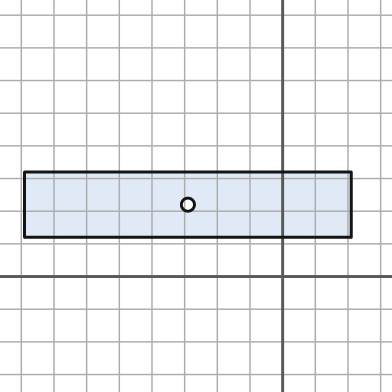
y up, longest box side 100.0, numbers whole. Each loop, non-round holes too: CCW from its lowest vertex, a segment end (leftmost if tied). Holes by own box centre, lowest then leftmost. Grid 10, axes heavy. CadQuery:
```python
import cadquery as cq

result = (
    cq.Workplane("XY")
    .moveTo(-79.0, 12.0)
    .lineTo(21.0, 12.0)
    .lineTo(21.0, 32.0)
    .lineTo(-79.0, 32.0)
    .close()
    .moveTo(-29.0, 22.0)
    .circle(2.0)
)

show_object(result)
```